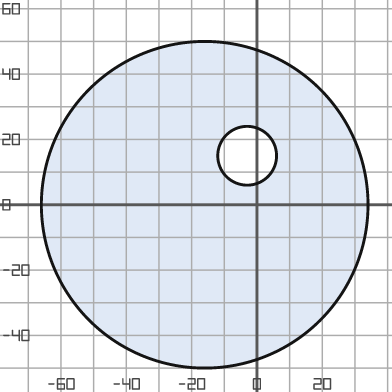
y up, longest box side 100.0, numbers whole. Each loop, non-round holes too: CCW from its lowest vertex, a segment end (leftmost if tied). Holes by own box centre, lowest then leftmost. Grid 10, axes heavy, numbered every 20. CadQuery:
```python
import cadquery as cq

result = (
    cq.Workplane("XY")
    .moveTo(-16.0, 0.0)
    .circle(50.0)
    .moveTo(-3.0, 15.0)
    .circle(9.0)
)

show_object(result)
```